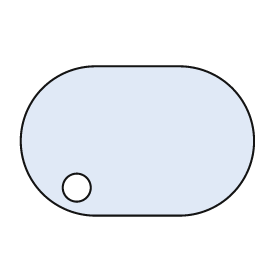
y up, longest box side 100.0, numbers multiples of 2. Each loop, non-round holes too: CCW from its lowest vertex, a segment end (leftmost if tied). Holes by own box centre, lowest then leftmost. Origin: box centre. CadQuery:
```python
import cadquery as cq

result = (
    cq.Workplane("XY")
    .moveTo(-18.0, -32.0)
    .lineTo(18.0, -32.0)
    .threePointArc((50.0, 0.0), (18.0, 32.0))
    .lineTo(-18.0, 32.0)
    .threePointArc((-50.0, 0.0), (-18.0, -32.0))
    .close()
    .moveTo(-26.0, -20.0)
    .circle(6.0)
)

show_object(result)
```